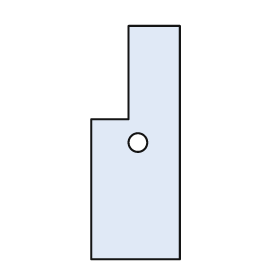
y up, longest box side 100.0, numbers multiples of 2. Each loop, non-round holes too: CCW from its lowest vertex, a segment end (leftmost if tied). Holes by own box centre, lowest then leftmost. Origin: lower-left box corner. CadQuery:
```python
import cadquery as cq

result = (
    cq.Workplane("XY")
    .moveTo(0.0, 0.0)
    .lineTo(38.0, 0.0)
    .lineTo(38.0, 100.0)
    .lineTo(16.0, 100.0)
    .lineTo(16.0, 60.0)
    .lineTo(0.0, 60.0)
    .close()
    .moveTo(20.0, 50.0)
    .circle(4.0)
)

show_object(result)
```